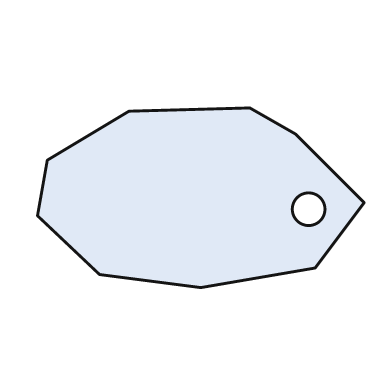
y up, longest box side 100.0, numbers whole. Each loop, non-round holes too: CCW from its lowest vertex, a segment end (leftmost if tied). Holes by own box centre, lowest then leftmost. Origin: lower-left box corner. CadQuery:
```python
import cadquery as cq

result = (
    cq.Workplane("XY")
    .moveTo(50.0, 0.0)
    .lineTo(85.0, 6.0)
    .lineTo(100.0, 26.0)
    .lineTo(79.0, 47.0)
    .lineTo(65.0, 55.0)
    .lineTo(28.0, 54.0)
    .lineTo(3.0, 39.0)
    .lineTo(0.0, 22.0)
    .lineTo(19.0, 4.0)
    .close()
    .moveTo(83.0, 24.0)
    .circle(5.0)
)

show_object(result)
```